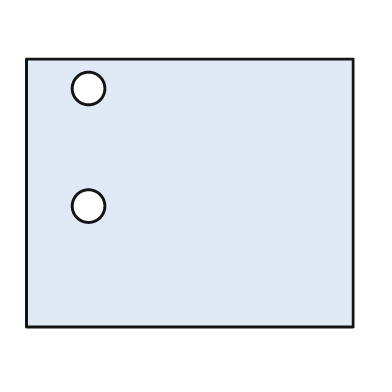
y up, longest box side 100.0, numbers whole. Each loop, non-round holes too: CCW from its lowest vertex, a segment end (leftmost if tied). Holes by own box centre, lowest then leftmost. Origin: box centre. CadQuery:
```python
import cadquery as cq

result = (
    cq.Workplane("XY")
    .moveTo(-50.0, -41.0)
    .lineTo(50.0, -41.0)
    .lineTo(50.0, 41.0)
    .lineTo(-50.0, 41.0)
    .close()
    .moveTo(-31.0, -4.0)
    .circle(5.0)
    .moveTo(-31.0, 32.0)
    .circle(5.0)
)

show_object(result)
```